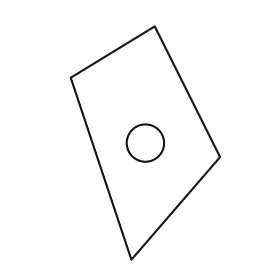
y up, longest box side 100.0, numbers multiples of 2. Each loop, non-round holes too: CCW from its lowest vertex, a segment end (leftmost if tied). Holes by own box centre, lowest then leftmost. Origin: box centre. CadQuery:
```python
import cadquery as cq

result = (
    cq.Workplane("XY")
    .moveTo(-6.0, -50.0)
    .lineTo(32.0, -6.0)
    .lineTo(4.0, 50.0)
    .lineTo(-32.0, 28.0)
    .close()
    .moveTo(0.0, 0.0)
    .circle(8.0)
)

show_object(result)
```